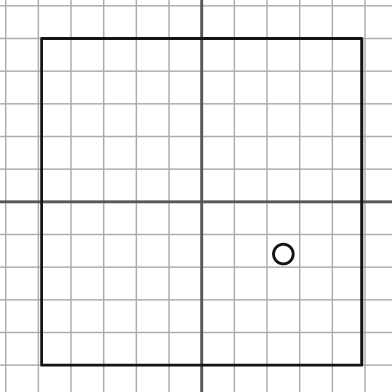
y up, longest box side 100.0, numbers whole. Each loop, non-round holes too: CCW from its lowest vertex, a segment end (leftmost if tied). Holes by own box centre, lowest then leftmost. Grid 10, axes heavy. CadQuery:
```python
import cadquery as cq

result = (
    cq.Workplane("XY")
    .moveTo(-49.0, -50.0)
    .lineTo(49.0, -50.0)
    .lineTo(49.0, 50.0)
    .lineTo(-49.0, 50.0)
    .close()
    .moveTo(25.0, -16.0)
    .circle(3.0)
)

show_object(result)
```